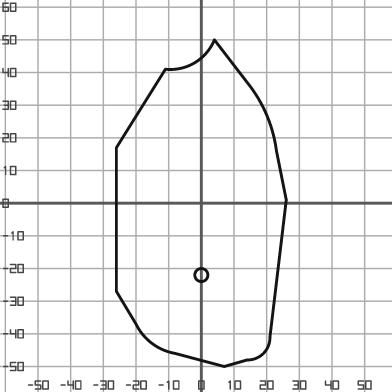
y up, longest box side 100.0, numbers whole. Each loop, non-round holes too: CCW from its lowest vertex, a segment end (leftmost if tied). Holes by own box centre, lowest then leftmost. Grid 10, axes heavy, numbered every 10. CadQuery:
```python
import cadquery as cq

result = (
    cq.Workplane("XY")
    .moveTo(7.0, -50.0)
    .lineTo(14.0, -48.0)
    .threePointArc((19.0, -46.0), (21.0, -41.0))
    .lineTo(26.0, 1.0)
    .lineTo(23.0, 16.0)
    .threePointArc((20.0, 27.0), (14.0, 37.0))
    .lineTo(4.0, 50.0)
    .threePointArc((-2.0, 43.0), (-11.0, 41.0))
    .lineTo(-26.0, 17.0)
    .lineTo(-26.0, -27.0)
    .lineTo(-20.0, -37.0)
    .threePointArc((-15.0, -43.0), (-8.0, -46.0))
    .close()
    .moveTo(0.0, -22.0)
    .circle(2.0)
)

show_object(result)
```